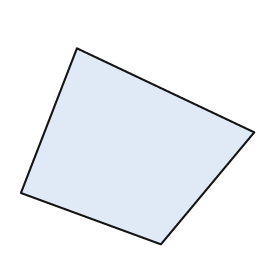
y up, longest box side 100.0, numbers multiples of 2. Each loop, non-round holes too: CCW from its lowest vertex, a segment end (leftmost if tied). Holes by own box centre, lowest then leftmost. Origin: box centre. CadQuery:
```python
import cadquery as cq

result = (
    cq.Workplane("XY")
    .moveTo(10.0, -42.0)
    .lineTo(50.0, 6.0)
    .lineTo(-26.0, 42.0)
    .lineTo(-50.0, -20.0)
    .close()
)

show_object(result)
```